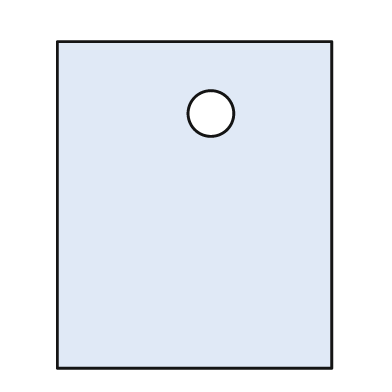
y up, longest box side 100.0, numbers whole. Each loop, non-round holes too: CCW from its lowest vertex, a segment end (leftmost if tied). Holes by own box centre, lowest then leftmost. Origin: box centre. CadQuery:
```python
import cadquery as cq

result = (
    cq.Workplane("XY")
    .moveTo(-42.0, -50.0)
    .lineTo(42.0, -50.0)
    .lineTo(42.0, 50.0)
    .lineTo(-42.0, 50.0)
    .close()
    .moveTo(5.0, 28.0)
    .circle(7.0)
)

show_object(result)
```